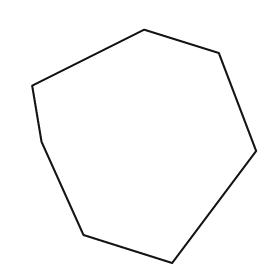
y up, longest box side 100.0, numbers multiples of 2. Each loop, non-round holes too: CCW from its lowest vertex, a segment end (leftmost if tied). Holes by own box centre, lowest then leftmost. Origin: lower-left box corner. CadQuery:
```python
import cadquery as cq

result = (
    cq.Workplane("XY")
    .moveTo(60.0, 0.0)
    .lineTo(96.0, 48.0)
    .lineTo(80.0, 90.0)
    .lineTo(48.0, 100.0)
    .lineTo(0.0, 76.0)
    .lineTo(4.0, 52.0)
    .lineTo(22.0, 12.0)
    .close()
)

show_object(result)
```